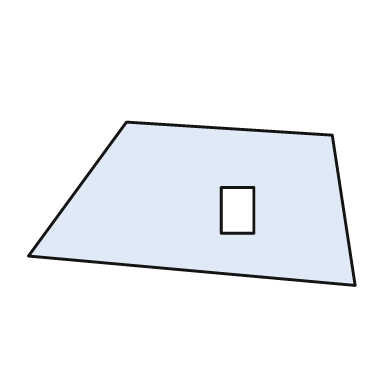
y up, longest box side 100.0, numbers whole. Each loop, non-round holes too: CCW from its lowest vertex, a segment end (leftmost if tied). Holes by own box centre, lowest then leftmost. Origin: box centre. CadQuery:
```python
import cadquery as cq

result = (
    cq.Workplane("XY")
    .moveTo(50.0, -25.0)
    .lineTo(43.0, 21.0)
    .lineTo(-20.0, 25.0)
    .lineTo(-50.0, -16.0)
    .close()
    .moveTo(9.0, -9.0)
    .lineTo(19.0, -9.0)
    .lineTo(19.0, 5.0)
    .lineTo(9.0, 5.0)
    .close()
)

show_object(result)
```